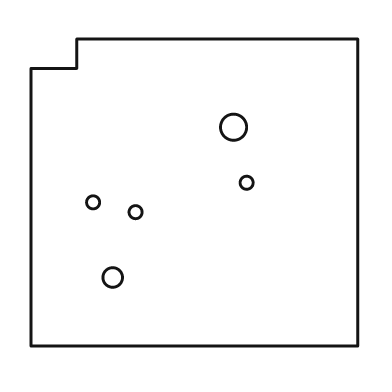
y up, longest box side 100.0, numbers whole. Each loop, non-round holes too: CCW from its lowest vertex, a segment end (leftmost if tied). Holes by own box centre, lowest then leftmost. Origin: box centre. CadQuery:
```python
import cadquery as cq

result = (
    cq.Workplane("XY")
    .moveTo(-50.0, -47.0)
    .lineTo(50.0, -47.0)
    .lineTo(50.0, 47.0)
    .lineTo(-36.0, 47.0)
    .lineTo(-36.0, 38.0)
    .lineTo(-50.0, 38.0)
    .close()
    .moveTo(-25.0, -26.0)
    .circle(3.0)
    .moveTo(-18.0, -6.0)
    .circle(2.0)
    .moveTo(-31.0, -3.0)
    .circle(2.0)
    .moveTo(16.0, 3.0)
    .circle(2.0)
    .moveTo(12.0, 20.0)
    .circle(4.0)
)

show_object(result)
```